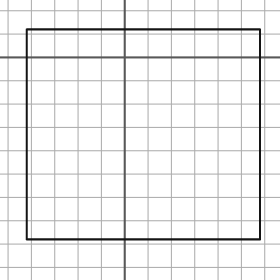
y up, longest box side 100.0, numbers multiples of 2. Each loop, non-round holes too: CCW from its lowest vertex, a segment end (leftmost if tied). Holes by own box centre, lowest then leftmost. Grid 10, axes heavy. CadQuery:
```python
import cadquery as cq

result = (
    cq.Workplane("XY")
    .moveTo(-42.0, -78.0)
    .lineTo(58.0, -78.0)
    .lineTo(58.0, 12.0)
    .lineTo(-42.0, 12.0)
    .close()
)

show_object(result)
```